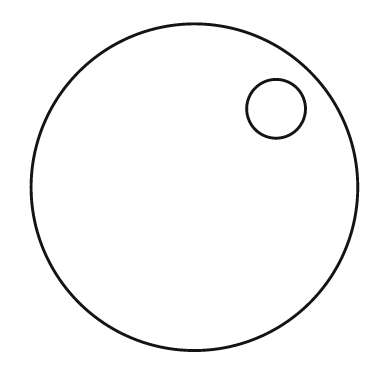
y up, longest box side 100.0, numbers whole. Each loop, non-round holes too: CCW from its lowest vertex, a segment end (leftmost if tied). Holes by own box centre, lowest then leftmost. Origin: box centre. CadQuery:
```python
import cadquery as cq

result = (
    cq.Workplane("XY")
    .moveTo(0.0, 0.0)
    .circle(50.0)
    .moveTo(25.0, 24.0)
    .circle(9.0)
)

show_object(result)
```